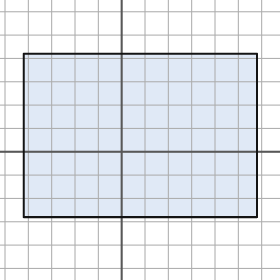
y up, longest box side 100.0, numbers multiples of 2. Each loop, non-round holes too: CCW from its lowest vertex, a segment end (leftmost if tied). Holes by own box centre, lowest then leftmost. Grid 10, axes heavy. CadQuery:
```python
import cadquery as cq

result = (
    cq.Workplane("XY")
    .moveTo(-42.0, -28.0)
    .lineTo(58.0, -28.0)
    .lineTo(58.0, 42.0)
    .lineTo(-42.0, 42.0)
    .close()
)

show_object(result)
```